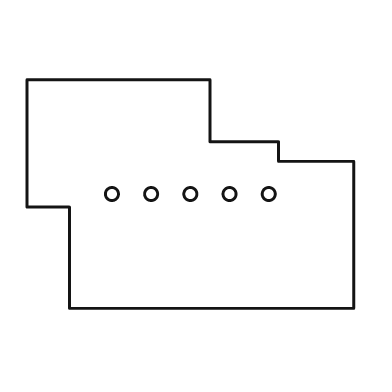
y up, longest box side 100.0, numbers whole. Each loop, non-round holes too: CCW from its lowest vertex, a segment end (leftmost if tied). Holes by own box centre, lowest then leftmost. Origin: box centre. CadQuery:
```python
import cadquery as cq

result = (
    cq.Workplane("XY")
    .moveTo(-37.0, -35.0)
    .lineTo(50.0, -35.0)
    .lineTo(50.0, 10.0)
    .lineTo(27.0, 10.0)
    .lineTo(27.0, 16.0)
    .lineTo(6.0, 16.0)
    .lineTo(6.0, 35.0)
    .lineTo(-50.0, 35.0)
    .lineTo(-50.0, -4.0)
    .lineTo(-37.0, -4.0)
    .close()
    .moveTo(-24.0, 0.0)
    .circle(2.0)
    .moveTo(-12.0, 0.0)
    .circle(2.0)
    .moveTo(0.0, 0.0)
    .circle(2.0)
    .moveTo(12.0, 0.0)
    .circle(2.0)
    .moveTo(24.0, 0.0)
    .circle(2.0)
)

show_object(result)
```